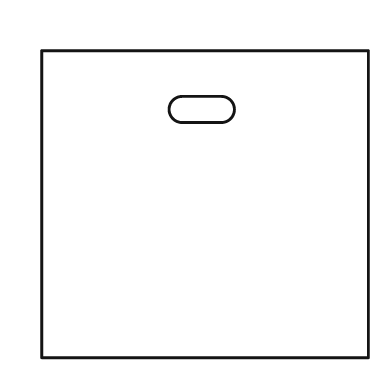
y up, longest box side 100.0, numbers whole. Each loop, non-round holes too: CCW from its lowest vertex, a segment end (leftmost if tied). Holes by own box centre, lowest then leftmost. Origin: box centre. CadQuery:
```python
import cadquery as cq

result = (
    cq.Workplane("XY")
    .moveTo(-50.0, -47.0)
    .lineTo(50.0, -47.0)
    .lineTo(50.0, 47.0)
    .lineTo(-50.0, 47.0)
    .close()
    .moveTo(-7.0, 25.0)
    .lineTo(5.0, 25.0)
    .threePointArc((9.0, 29.0), (5.0, 33.0))
    .lineTo(-7.0, 33.0)
    .threePointArc((-11.0, 29.0), (-7.0, 25.0))
    .close()
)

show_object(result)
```